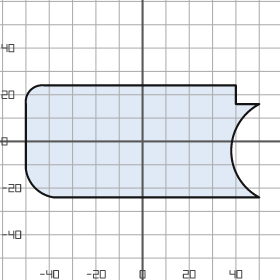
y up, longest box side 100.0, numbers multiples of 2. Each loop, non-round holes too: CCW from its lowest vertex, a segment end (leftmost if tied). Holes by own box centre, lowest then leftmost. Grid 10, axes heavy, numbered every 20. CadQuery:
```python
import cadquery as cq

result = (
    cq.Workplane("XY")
    .moveTo(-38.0, -24.0)
    .lineTo(50.0, -24.0)
    .threePointArc((38.0, -4.0), (50.0, 16.0))
    .lineTo(40.0, 16.0)
    .lineTo(40.0, 24.0)
    .lineTo(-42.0, 24.0)
    .threePointArc((-48.0, 22.0), (-50.0, 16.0))
    .lineTo(-50.0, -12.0)
    .threePointArc((-46.0, -20.0), (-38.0, -24.0))
    .close()
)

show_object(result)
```